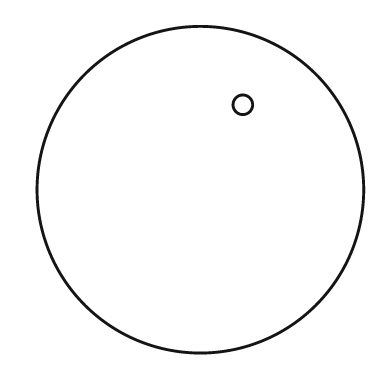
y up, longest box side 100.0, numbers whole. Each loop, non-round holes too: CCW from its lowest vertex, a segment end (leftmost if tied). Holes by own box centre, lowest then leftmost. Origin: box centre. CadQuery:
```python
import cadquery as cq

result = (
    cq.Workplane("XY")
    .moveTo(0.0, 0.0)
    .circle(50.0)
    .moveTo(13.0, 26.0)
    .circle(3.0)
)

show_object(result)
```